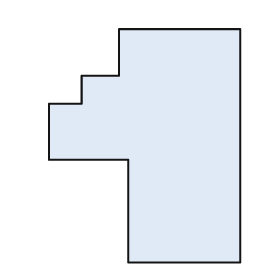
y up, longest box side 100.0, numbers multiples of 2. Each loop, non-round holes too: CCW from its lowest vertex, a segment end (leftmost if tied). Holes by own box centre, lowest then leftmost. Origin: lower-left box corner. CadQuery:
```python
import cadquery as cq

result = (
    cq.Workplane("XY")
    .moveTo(34.0, 0.0)
    .lineTo(82.0, 0.0)
    .lineTo(82.0, 100.0)
    .lineTo(30.0, 100.0)
    .lineTo(30.0, 80.0)
    .lineTo(14.0, 80.0)
    .lineTo(14.0, 68.0)
    .lineTo(0.0, 68.0)
    .lineTo(0.0, 44.0)
    .lineTo(34.0, 44.0)
    .close()
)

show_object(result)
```